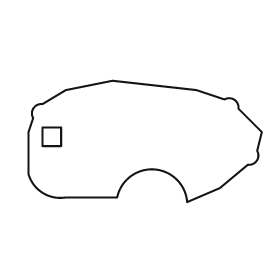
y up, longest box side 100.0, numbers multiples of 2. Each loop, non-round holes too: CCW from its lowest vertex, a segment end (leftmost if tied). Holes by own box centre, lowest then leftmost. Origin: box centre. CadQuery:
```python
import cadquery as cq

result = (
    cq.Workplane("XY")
    .moveTo(18.0, -26.0)
    .lineTo(32.0, -20.0)
    .lineTo(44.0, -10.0)
    .threePointArc((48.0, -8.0), (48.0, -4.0))
    .lineTo(50.0, 4.0)
    .lineTo(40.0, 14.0)
    .threePointArc((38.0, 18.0), (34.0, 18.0))
    .lineTo(22.0, 22.0)
    .lineTo(-14.0, 26.0)
    .lineTo(-34.0, 22.0)
    .lineTo(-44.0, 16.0)
    .threePointArc((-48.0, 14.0), (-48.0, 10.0))
    .lineTo(-50.0, 4.0)
    .lineTo(-50.0, -14.0)
    .threePointArc((-44.0, -22.0), (-34.0, -24.0))
    .lineTo(-12.0, -24.0)
    .threePointArc((4.0, -12.0), (18.0, -26.0))
    .close()
    .moveTo(-44.0, -2.0)
    .lineTo(-36.0, -2.0)
    .lineTo(-36.0, 6.0)
    .lineTo(-44.0, 6.0)
    .close()
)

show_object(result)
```